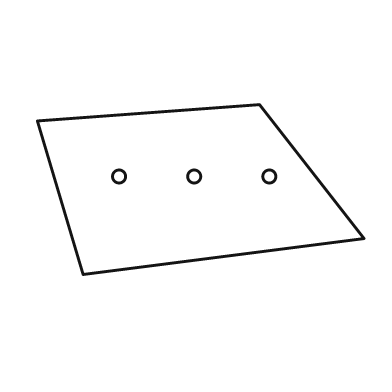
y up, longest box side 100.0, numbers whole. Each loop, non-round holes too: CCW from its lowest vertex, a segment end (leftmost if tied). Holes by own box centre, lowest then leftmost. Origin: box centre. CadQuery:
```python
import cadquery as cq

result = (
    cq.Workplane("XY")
    .moveTo(-36.0, -26.0)
    .lineTo(50.0, -15.0)
    .lineTo(18.0, 26.0)
    .lineTo(-50.0, 21.0)
    .close()
    .moveTo(-25.0, 4.0)
    .circle(2.0)
    .moveTo(-2.0, 4.0)
    .circle(2.0)
    .moveTo(21.0, 4.0)
    .circle(2.0)
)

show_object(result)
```